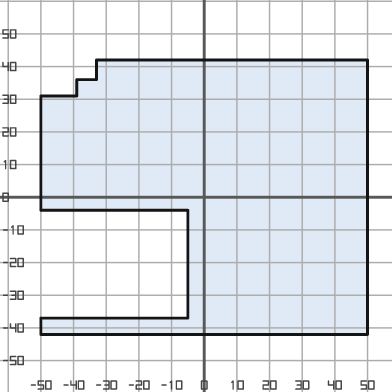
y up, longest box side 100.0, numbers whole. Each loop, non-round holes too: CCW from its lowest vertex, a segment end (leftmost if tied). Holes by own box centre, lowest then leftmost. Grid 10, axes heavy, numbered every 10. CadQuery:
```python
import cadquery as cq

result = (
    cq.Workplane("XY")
    .moveTo(-50.0, -42.0)
    .lineTo(50.0, -42.0)
    .lineTo(50.0, 42.0)
    .lineTo(-33.0, 42.0)
    .lineTo(-33.0, 36.0)
    .lineTo(-39.0, 36.0)
    .lineTo(-39.0, 31.0)
    .lineTo(-50.0, 31.0)
    .lineTo(-50.0, -4.0)
    .lineTo(-5.0, -4.0)
    .lineTo(-5.0, -37.0)
    .lineTo(-50.0, -37.0)
    .close()
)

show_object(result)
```